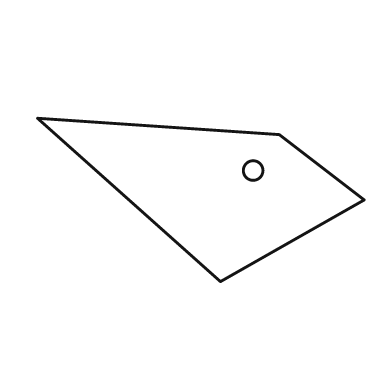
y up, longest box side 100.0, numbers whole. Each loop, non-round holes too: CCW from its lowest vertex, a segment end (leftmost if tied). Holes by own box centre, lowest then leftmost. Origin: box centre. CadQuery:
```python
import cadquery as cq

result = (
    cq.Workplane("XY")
    .moveTo(6.0, -25.0)
    .lineTo(50.0, 0.0)
    .lineTo(24.0, 20.0)
    .lineTo(-50.0, 25.0)
    .close()
    .moveTo(16.0, 9.0)
    .circle(3.0)
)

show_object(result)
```